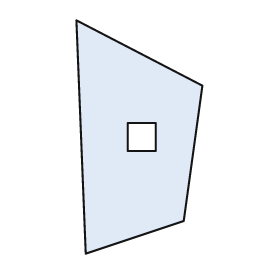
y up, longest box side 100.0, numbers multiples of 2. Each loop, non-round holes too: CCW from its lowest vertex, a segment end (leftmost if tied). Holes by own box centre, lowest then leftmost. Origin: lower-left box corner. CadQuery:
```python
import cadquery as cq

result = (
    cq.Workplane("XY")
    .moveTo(4.0, 0.0)
    .lineTo(46.0, 14.0)
    .lineTo(54.0, 72.0)
    .lineTo(0.0, 100.0)
    .close()
    .moveTo(22.0, 44.0)
    .lineTo(34.0, 44.0)
    .lineTo(34.0, 56.0)
    .lineTo(22.0, 56.0)
    .close()
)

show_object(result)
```